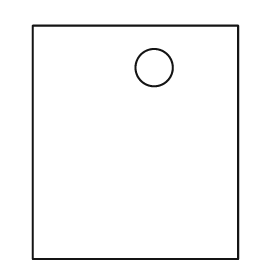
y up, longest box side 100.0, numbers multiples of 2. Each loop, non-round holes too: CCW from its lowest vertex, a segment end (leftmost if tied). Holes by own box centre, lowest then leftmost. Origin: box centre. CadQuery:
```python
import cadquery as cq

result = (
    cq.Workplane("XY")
    .moveTo(-44.0, -50.0)
    .lineTo(44.0, -50.0)
    .lineTo(44.0, 50.0)
    .lineTo(-44.0, 50.0)
    .close()
    .moveTo(8.0, 32.0)
    .circle(8.0)
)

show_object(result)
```